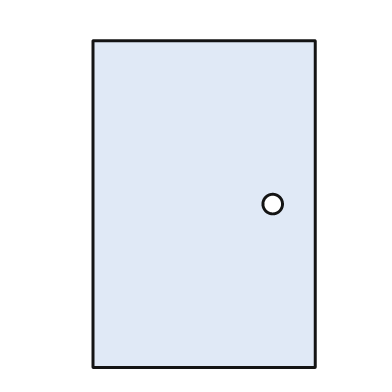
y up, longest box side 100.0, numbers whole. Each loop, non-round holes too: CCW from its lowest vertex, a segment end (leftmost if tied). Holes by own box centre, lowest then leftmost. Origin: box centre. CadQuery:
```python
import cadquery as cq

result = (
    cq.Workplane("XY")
    .moveTo(-34.0, -50.0)
    .lineTo(34.0, -50.0)
    .lineTo(34.0, 50.0)
    .lineTo(-34.0, 50.0)
    .close()
    .moveTo(21.0, 0.0)
    .circle(3.0)
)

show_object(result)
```